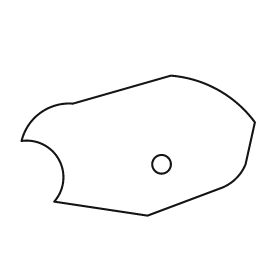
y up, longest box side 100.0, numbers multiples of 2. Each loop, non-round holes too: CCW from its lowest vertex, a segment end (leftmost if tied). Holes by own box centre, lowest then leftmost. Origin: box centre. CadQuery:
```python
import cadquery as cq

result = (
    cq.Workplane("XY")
    .moveTo(4.0, -30.0)
    .lineTo(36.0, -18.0)
    .threePointArc((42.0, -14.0), (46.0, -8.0))
    .lineTo(50.0, 10.0)
    .threePointArc((34.0, 24.0), (14.0, 30.0))
    .lineTo(-28.0, 18.0)
    .threePointArc((-42.0, 14.0), (-50.0, 2.0))
    .threePointArc((-34.0, -6.0), (-36.0, -24.0))
    .close()
    .moveTo(10.0, -8.0)
    .circle(4.0)
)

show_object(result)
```